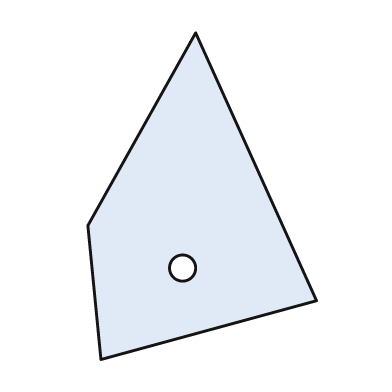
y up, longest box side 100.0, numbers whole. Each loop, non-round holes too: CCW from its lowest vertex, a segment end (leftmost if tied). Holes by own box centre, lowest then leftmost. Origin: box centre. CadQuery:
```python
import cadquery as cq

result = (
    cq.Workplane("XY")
    .moveTo(-31.0, -50.0)
    .lineTo(35.0, -32.0)
    .lineTo(-2.0, 50.0)
    .lineTo(-35.0, -9.0)
    .close()
    .moveTo(-6.0, -22.0)
    .circle(4.0)
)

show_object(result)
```